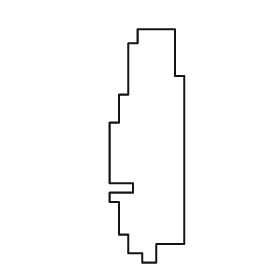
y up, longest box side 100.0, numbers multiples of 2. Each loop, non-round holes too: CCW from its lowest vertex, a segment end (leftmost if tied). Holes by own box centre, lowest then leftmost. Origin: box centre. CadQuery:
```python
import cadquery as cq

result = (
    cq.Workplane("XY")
    .moveTo(-2.0, -50.0)
    .lineTo(4.0, -50.0)
    .lineTo(4.0, -42.0)
    .lineTo(16.0, -42.0)
    .lineTo(16.0, 30.0)
    .lineTo(12.0, 30.0)
    .lineTo(12.0, 50.0)
    .lineTo(-4.0, 50.0)
    .lineTo(-4.0, 44.0)
    .lineTo(-8.0, 44.0)
    .lineTo(-8.0, 22.0)
    .lineTo(-12.0, 22.0)
    .lineTo(-12.0, 10.0)
    .lineTo(-16.0, 10.0)
    .lineTo(-16.0, -16.0)
    .lineTo(-6.0, -16.0)
    .lineTo(-6.0, -20.0)
    .lineTo(-16.0, -20.0)
    .lineTo(-16.0, -24.0)
    .lineTo(-12.0, -24.0)
    .lineTo(-12.0, -38.0)
    .lineTo(-8.0, -38.0)
    .lineTo(-8.0, -46.0)
    .lineTo(-2.0, -46.0)
    .close()
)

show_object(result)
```